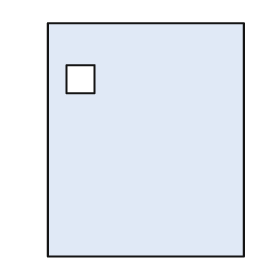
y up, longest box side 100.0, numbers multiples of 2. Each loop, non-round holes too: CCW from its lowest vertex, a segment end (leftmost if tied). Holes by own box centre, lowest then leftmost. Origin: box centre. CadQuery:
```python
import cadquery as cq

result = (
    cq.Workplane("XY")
    .moveTo(-42.0, -50.0)
    .lineTo(42.0, -50.0)
    .lineTo(42.0, 50.0)
    .lineTo(-42.0, 50.0)
    .close()
    .moveTo(-34.0, 20.0)
    .lineTo(-22.0, 20.0)
    .lineTo(-22.0, 32.0)
    .lineTo(-34.0, 32.0)
    .close()
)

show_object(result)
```